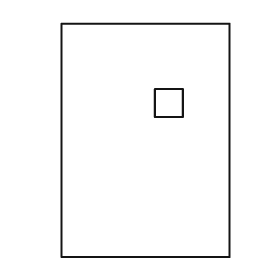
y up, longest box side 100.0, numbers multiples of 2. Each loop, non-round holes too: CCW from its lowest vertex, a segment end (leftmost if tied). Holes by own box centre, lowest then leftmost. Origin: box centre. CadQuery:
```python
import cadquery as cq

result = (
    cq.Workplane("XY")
    .moveTo(-36.0, -50.0)
    .lineTo(36.0, -50.0)
    .lineTo(36.0, 50.0)
    .lineTo(-36.0, 50.0)
    .close()
    .moveTo(4.0, 10.0)
    .lineTo(16.0, 10.0)
    .lineTo(16.0, 22.0)
    .lineTo(4.0, 22.0)
    .close()
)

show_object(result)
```